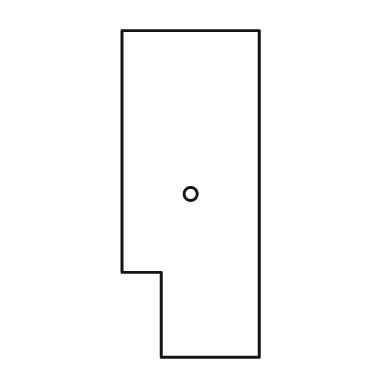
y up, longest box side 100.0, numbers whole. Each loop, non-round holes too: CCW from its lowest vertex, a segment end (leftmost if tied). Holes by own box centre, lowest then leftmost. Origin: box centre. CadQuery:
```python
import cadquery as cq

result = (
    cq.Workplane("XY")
    .moveTo(-9.0, -50.0)
    .lineTo(21.0, -50.0)
    .lineTo(21.0, 50.0)
    .lineTo(-21.0, 50.0)
    .lineTo(-21.0, -24.0)
    .lineTo(-9.0, -24.0)
    .close()
    .moveTo(0.0, 0.0)
    .circle(2.0)
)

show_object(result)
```